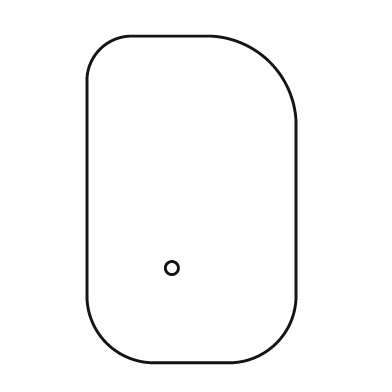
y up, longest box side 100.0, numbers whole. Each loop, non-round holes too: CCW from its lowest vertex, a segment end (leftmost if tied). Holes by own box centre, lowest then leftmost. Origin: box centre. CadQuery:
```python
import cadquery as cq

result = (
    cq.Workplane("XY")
    .moveTo(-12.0, -50.0)
    .lineTo(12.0, -50.0)
    .threePointArc((26.0, -44.0), (32.0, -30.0))
    .lineTo(32.0, 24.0)
    .threePointArc((24.0, 42.0), (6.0, 50.0))
    .lineTo(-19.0, 50.0)
    .threePointArc((-28.0, 46.0), (-32.0, 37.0))
    .lineTo(-32.0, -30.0)
    .threePointArc((-26.0, -44.0), (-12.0, -50.0))
    .close()
    .moveTo(-6.0, -21.0)
    .circle(2.0)
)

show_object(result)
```